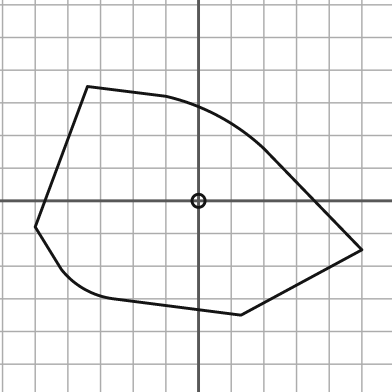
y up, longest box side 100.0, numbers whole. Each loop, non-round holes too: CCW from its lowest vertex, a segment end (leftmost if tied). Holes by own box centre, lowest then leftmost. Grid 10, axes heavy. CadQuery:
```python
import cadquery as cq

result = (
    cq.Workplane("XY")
    .moveTo(13.0, -35.0)
    .lineTo(50.0, -15.0)
    .lineTo(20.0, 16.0)
    .threePointArc((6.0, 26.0), (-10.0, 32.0))
    .lineTo(-34.0, 35.0)
    .lineTo(-50.0, -8.0)
    .lineTo(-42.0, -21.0)
    .threePointArc((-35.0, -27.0), (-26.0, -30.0))
    .close()
    .moveTo(0.0, 0.0)
    .circle(2.0)
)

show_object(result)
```